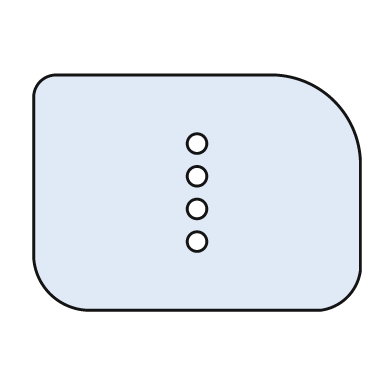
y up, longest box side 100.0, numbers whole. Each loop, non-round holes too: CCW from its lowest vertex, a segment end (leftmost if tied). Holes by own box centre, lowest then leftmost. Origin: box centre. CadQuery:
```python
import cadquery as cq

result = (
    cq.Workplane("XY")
    .moveTo(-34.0, -36.0)
    .lineTo(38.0, -36.0)
    .threePointArc((46.0, -32.0), (50.0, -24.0))
    .lineTo(50.0, 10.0)
    .threePointArc((42.0, 28.0), (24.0, 36.0))
    .lineTo(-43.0, 36.0)
    .threePointArc((-48.0, 34.0), (-50.0, 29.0))
    .lineTo(-50.0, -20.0)
    .threePointArc((-45.0, -31.0), (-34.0, -36.0))
    .close()
    .moveTo(0.0, -15.0)
    .circle(3.0)
    .moveTo(0.0, -5.0)
    .circle(3.0)
    .moveTo(0.0, 5.0)
    .circle(3.0)
    .moveTo(0.0, 15.0)
    .circle(3.0)
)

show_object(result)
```